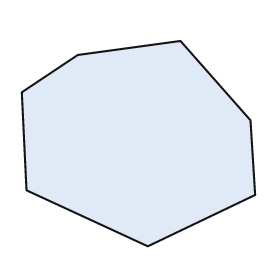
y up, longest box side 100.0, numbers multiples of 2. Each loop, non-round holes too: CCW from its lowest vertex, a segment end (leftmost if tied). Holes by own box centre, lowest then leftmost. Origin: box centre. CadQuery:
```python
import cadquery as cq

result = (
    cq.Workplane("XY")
    .moveTo(4.0, -44.0)
    .lineTo(50.0, -22.0)
    .lineTo(48.0, 10.0)
    .lineTo(18.0, 44.0)
    .lineTo(-26.0, 38.0)
    .lineTo(-50.0, 22.0)
    .lineTo(-48.0, -20.0)
    .close()
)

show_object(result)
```